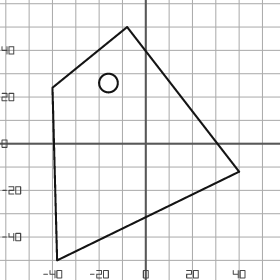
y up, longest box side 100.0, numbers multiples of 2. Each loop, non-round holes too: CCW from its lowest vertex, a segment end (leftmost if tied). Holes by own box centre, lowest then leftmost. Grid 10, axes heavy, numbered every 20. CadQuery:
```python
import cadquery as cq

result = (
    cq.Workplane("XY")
    .moveTo(-38.0, -50.0)
    .lineTo(40.0, -12.0)
    .lineTo(-8.0, 50.0)
    .lineTo(-40.0, 24.0)
    .close()
    .moveTo(-16.0, 26.0)
    .circle(4.0)
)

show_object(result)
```